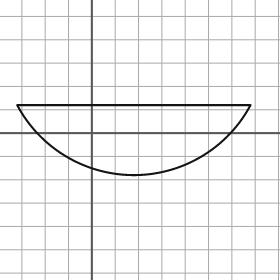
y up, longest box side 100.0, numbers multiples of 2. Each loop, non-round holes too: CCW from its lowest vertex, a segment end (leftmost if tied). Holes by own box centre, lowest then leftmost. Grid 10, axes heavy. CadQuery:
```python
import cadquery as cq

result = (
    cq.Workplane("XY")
    .moveTo(-32.0, 12.0)
    .threePointArc((18.0, -18.0), (68.0, 12.0))
    .close()
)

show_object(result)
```